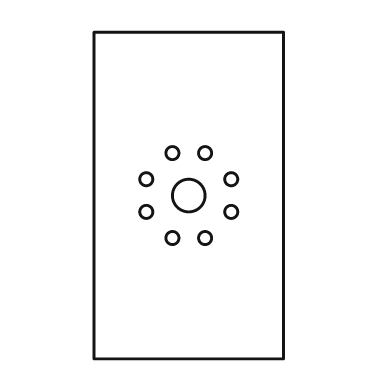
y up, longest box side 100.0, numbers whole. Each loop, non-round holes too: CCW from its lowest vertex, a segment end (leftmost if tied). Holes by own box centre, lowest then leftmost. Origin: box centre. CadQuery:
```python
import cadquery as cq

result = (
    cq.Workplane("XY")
    .moveTo(-29.0, -50.0)
    .lineTo(29.0, -50.0)
    .lineTo(29.0, 50.0)
    .lineTo(-29.0, 50.0)
    .close()
    .moveTo(-5.0, -13.0)
    .circle(2.0)
    .moveTo(5.0, -13.0)
    .circle(2.0)
    .moveTo(-13.0, -5.0)
    .circle(2.0)
    .moveTo(13.0, -5.0)
    .circle(2.0)
    .moveTo(0.0, 0.0)
    .circle(5.0)
    .moveTo(-13.0, 5.0)
    .circle(2.0)
    .moveTo(13.0, 5.0)
    .circle(2.0)
    .moveTo(-5.0, 13.0)
    .circle(2.0)
    .moveTo(5.0, 13.0)
    .circle(2.0)
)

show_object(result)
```